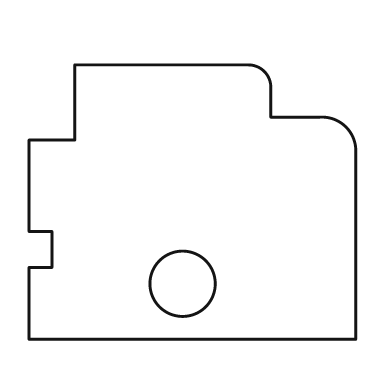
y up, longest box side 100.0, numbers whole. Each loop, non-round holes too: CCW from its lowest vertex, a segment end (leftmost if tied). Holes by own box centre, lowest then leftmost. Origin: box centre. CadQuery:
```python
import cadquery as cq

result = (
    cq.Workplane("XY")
    .moveTo(-50.0, -42.0)
    .lineTo(50.0, -42.0)
    .lineTo(50.0, 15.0)
    .threePointArc((47.0, 23.0), (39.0, 26.0))
    .lineTo(24.0, 26.0)
    .lineTo(24.0, 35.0)
    .threePointArc((22.0, 40.0), (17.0, 42.0))
    .lineTo(-36.0, 42.0)
    .lineTo(-36.0, 19.0)
    .lineTo(-50.0, 19.0)
    .lineTo(-50.0, -9.0)
    .lineTo(-43.0, -9.0)
    .lineTo(-43.0, -20.0)
    .lineTo(-50.0, -20.0)
    .close()
    .moveTo(-3.0, -25.0)
    .circle(10.0)
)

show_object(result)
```